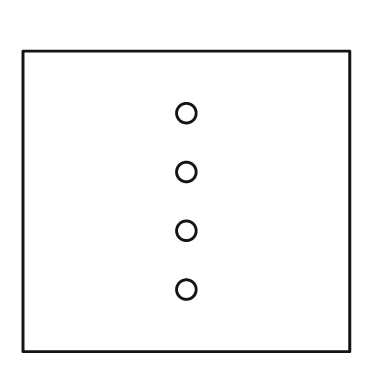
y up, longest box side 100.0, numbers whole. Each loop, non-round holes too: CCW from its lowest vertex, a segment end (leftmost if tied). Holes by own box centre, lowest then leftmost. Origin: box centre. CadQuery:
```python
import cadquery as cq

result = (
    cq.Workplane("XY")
    .moveTo(-50.0, -46.0)
    .lineTo(50.0, -46.0)
    .lineTo(50.0, 46.0)
    .lineTo(-50.0, 46.0)
    .close()
    .moveTo(0.0, -27.0)
    .circle(3.0)
    .moveTo(0.0, -9.0)
    .circle(3.0)
    .moveTo(0.0, 9.0)
    .circle(3.0)
    .moveTo(0.0, 27.0)
    .circle(3.0)
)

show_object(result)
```